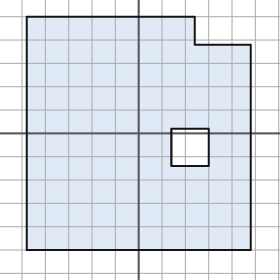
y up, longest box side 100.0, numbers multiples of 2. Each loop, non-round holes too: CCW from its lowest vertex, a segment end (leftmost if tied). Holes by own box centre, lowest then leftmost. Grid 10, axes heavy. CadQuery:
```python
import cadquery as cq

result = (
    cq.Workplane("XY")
    .moveTo(-48.0, -50.0)
    .lineTo(48.0, -50.0)
    .lineTo(48.0, 38.0)
    .lineTo(24.0, 38.0)
    .lineTo(24.0, 50.0)
    .lineTo(-48.0, 50.0)
    .close()
    .moveTo(14.0, -14.0)
    .lineTo(30.0, -14.0)
    .lineTo(30.0, 2.0)
    .lineTo(14.0, 2.0)
    .close()
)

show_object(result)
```